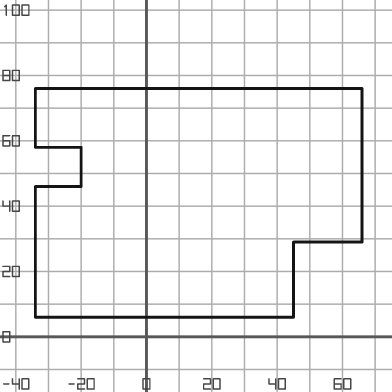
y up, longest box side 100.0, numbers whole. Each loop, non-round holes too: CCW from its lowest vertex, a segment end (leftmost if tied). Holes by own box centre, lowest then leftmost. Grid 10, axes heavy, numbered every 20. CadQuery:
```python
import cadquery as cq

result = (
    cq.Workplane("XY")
    .moveTo(-34.0, 6.0)
    .lineTo(45.0, 6.0)
    .lineTo(45.0, 29.0)
    .lineTo(66.0, 29.0)
    .lineTo(66.0, 76.0)
    .lineTo(-34.0, 76.0)
    .lineTo(-34.0, 58.0)
    .lineTo(-20.0, 58.0)
    .lineTo(-20.0, 46.0)
    .lineTo(-34.0, 46.0)
    .close()
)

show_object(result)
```